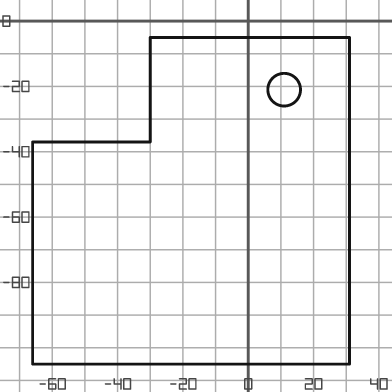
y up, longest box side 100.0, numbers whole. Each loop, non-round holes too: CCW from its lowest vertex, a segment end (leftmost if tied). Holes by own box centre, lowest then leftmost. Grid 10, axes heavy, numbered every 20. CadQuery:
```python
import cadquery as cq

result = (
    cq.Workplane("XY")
    .moveTo(-66.0, -105.0)
    .lineTo(31.0, -105.0)
    .lineTo(31.0, -5.0)
    .lineTo(-30.0, -5.0)
    .lineTo(-30.0, -37.0)
    .lineTo(-66.0, -37.0)
    .close()
    .moveTo(11.0, -21.0)
    .circle(5.0)
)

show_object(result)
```